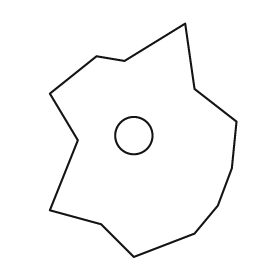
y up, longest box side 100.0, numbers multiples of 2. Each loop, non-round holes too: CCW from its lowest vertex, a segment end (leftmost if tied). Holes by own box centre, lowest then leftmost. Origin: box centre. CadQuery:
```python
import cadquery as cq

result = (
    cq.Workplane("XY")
    .moveTo(-4.0, -50.0)
    .lineTo(22.0, -40.0)
    .lineTo(32.0, -28.0)
    .lineTo(38.0, -12.0)
    .lineTo(40.0, 8.0)
    .lineTo(22.0, 22.0)
    .lineTo(18.0, 50.0)
    .lineTo(-8.0, 34.0)
    .lineTo(-20.0, 36.0)
    .lineTo(-40.0, 20.0)
    .lineTo(-28.0, 0.0)
    .lineTo(-40.0, -30.0)
    .lineTo(-18.0, -36.0)
    .close()
    .moveTo(-4.0, 2.0)
    .circle(8.0)
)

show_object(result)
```